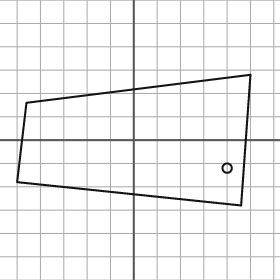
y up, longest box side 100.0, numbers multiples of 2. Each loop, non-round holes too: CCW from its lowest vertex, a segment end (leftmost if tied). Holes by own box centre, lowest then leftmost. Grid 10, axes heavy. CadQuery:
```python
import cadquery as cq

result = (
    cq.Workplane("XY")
    .moveTo(46.0, -28.0)
    .lineTo(50.0, 28.0)
    .lineTo(-46.0, 16.0)
    .lineTo(-50.0, -18.0)
    .close()
    .moveTo(40.0, -12.0)
    .circle(2.0)
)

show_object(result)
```